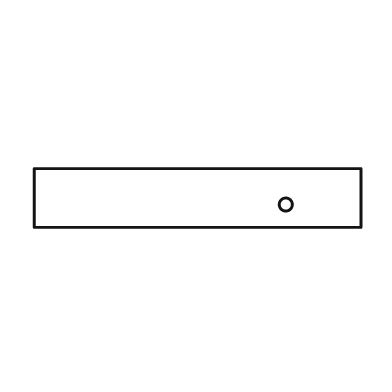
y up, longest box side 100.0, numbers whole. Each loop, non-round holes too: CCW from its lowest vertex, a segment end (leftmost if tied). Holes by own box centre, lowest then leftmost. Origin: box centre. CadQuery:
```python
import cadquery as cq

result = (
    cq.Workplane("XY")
    .moveTo(-50.0, -9.0)
    .lineTo(50.0, -9.0)
    .lineTo(50.0, 9.0)
    .lineTo(-50.0, 9.0)
    .close()
    .moveTo(27.0, -2.0)
    .circle(2.0)
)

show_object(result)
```